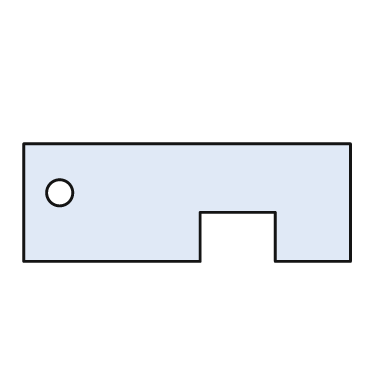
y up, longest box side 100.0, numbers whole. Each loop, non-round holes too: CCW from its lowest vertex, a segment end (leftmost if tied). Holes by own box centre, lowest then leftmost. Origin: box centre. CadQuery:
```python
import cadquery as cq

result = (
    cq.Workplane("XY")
    .moveTo(-50.0, -18.0)
    .lineTo(4.0, -18.0)
    .lineTo(4.0, -3.0)
    .lineTo(27.0, -3.0)
    .lineTo(27.0, -18.0)
    .lineTo(50.0, -18.0)
    .lineTo(50.0, 18.0)
    .lineTo(-50.0, 18.0)
    .close()
    .moveTo(-39.0, 3.0)
    .circle(4.0)
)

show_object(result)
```